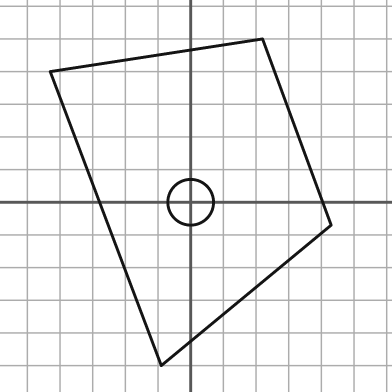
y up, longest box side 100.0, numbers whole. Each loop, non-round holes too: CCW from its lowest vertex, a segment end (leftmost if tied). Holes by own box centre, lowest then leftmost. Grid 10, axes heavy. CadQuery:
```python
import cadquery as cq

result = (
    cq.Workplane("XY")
    .moveTo(-9.0, -50.0)
    .lineTo(43.0, -7.0)
    .lineTo(22.0, 50.0)
    .lineTo(-43.0, 40.0)
    .close()
    .moveTo(0.0, 0.0)
    .circle(7.0)
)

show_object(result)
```